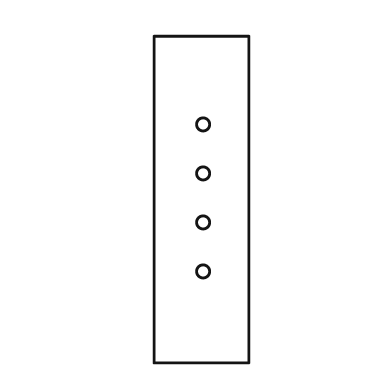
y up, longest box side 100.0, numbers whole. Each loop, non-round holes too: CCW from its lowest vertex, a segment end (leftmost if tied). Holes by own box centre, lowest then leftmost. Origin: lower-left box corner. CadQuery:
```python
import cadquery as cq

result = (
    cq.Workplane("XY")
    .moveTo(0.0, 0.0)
    .lineTo(29.0, 0.0)
    .lineTo(29.0, 100.0)
    .lineTo(0.0, 100.0)
    .close()
    .moveTo(15.0, 28.0)
    .circle(2.0)
    .moveTo(15.0, 43.0)
    .circle(2.0)
    .moveTo(15.0, 58.0)
    .circle(2.0)
    .moveTo(15.0, 73.0)
    .circle(2.0)
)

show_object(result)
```